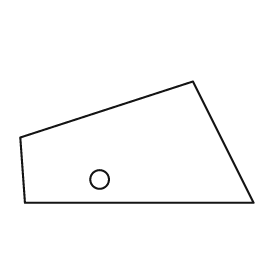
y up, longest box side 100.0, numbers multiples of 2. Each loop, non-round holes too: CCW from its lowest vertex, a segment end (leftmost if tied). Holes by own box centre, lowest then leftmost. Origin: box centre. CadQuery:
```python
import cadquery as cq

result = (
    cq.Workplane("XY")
    .moveTo(-48.0, -26.0)
    .lineTo(50.0, -26.0)
    .lineTo(24.0, 26.0)
    .lineTo(-50.0, 2.0)
    .close()
    .moveTo(-16.0, -16.0)
    .circle(4.0)
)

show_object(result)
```